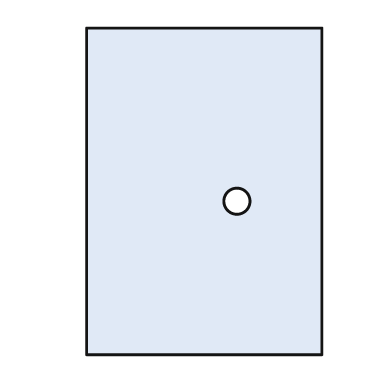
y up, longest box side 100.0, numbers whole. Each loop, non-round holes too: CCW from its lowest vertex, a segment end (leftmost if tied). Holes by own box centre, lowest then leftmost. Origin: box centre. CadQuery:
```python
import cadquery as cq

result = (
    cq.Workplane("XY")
    .moveTo(-36.0, -50.0)
    .lineTo(36.0, -50.0)
    .lineTo(36.0, 50.0)
    .lineTo(-36.0, 50.0)
    .close()
    .moveTo(10.0, -3.0)
    .circle(4.0)
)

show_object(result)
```